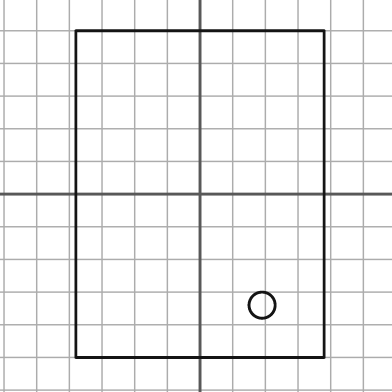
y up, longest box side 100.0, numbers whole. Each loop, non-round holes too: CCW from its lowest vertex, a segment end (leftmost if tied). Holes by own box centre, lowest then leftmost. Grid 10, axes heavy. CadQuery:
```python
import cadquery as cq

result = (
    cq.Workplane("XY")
    .moveTo(-38.0, -50.0)
    .lineTo(38.0, -50.0)
    .lineTo(38.0, 50.0)
    .lineTo(-38.0, 50.0)
    .close()
    .moveTo(19.0, -34.0)
    .circle(4.0)
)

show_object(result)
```